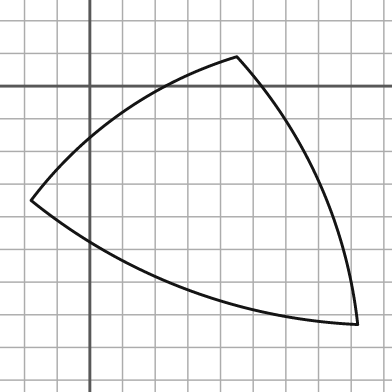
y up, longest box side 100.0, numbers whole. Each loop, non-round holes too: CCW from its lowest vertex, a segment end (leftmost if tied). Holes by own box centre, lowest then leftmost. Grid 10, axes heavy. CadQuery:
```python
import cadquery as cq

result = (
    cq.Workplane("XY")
    .moveTo(82.0, -73.0)
    .threePointArc((70.0, -29.0), (45.0, 9.0))
    .threePointArc((10.0, -8.0), (-18.0, -35.0))
    .threePointArc((29.0, -62.0), (82.0, -73.0))
    .close()
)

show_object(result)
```